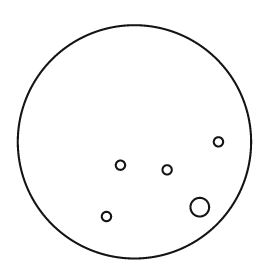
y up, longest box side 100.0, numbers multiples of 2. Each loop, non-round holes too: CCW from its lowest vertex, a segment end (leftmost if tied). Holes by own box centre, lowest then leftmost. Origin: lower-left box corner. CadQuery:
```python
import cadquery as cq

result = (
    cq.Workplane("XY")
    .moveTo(50.0, 50.0)
    .circle(50.0)
    .moveTo(38.0, 18.0)
    .circle(2.0)
    .moveTo(78.0, 22.0)
    .circle(4.0)
    .moveTo(64.0, 38.0)
    .circle(2.0)
    .moveTo(44.0, 40.0)
    .circle(2.0)
    .moveTo(86.0, 50.0)
    .circle(2.0)
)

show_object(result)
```